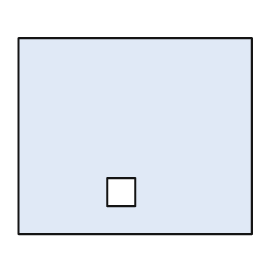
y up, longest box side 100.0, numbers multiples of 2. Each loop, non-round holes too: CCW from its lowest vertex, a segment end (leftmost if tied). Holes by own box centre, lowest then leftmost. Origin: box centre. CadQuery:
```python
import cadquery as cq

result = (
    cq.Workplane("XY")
    .moveTo(-50.0, -42.0)
    .lineTo(50.0, -42.0)
    .lineTo(50.0, 42.0)
    .lineTo(-50.0, 42.0)
    .close()
    .moveTo(-12.0, -30.0)
    .lineTo(0.0, -30.0)
    .lineTo(0.0, -18.0)
    .lineTo(-12.0, -18.0)
    .close()
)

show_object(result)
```